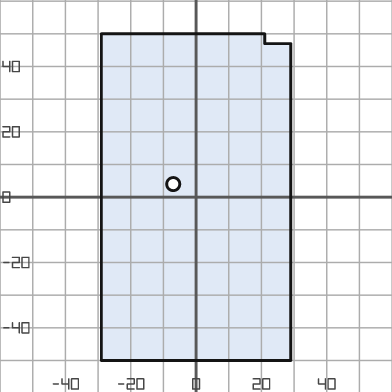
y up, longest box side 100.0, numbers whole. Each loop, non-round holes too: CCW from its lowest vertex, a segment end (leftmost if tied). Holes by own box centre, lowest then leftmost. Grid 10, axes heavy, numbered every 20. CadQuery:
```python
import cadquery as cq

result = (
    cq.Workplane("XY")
    .moveTo(-29.0, -50.0)
    .lineTo(29.0, -50.0)
    .lineTo(29.0, 47.0)
    .lineTo(21.0, 47.0)
    .lineTo(21.0, 50.0)
    .lineTo(-29.0, 50.0)
    .close()
    .moveTo(-7.0, 4.0)
    .circle(2.0)
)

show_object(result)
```